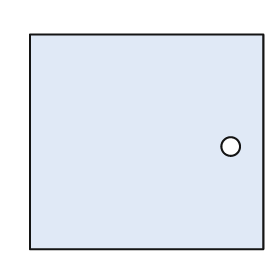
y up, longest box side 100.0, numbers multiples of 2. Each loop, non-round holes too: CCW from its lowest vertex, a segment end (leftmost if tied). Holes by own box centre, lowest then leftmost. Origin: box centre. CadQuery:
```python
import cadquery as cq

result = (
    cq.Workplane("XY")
    .moveTo(-50.0, -46.0)
    .lineTo(50.0, -46.0)
    .lineTo(50.0, 46.0)
    .lineTo(-50.0, 46.0)
    .close()
    .moveTo(36.0, -2.0)
    .circle(4.0)
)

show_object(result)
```